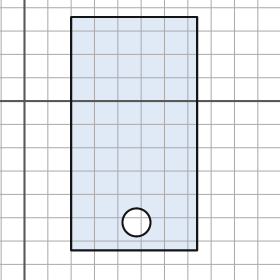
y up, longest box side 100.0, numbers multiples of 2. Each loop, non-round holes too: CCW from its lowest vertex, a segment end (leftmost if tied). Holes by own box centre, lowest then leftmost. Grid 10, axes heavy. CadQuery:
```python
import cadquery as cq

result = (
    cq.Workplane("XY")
    .moveTo(20.0, -64.0)
    .lineTo(74.0, -64.0)
    .lineTo(74.0, 36.0)
    .lineTo(20.0, 36.0)
    .close()
    .moveTo(48.0, -52.0)
    .circle(6.0)
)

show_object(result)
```